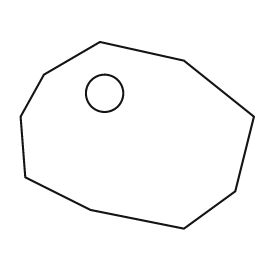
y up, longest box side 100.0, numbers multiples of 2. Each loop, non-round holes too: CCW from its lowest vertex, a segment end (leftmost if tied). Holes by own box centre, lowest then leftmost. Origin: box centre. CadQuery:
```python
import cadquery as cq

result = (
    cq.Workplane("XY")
    .moveTo(20.0, -40.0)
    .lineTo(42.0, -24.0)
    .lineTo(50.0, 8.0)
    .lineTo(20.0, 32.0)
    .lineTo(-16.0, 40.0)
    .lineTo(-40.0, 26.0)
    .lineTo(-50.0, 8.0)
    .lineTo(-48.0, -18.0)
    .lineTo(-20.0, -32.0)
    .close()
    .moveTo(-14.0, 18.0)
    .circle(8.0)
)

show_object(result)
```